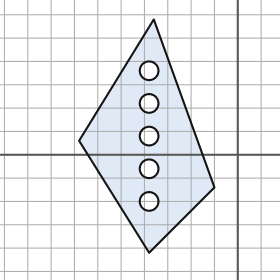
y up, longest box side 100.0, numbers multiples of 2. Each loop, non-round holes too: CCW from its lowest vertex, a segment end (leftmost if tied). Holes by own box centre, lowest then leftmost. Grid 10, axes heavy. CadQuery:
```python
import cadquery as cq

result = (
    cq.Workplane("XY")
    .moveTo(-38.0, -42.0)
    .lineTo(-10.0, -14.0)
    .lineTo(-36.0, 58.0)
    .lineTo(-68.0, 6.0)
    .close()
    .moveTo(-38.0, -20.0)
    .circle(4.0)
    .moveTo(-38.0, -6.0)
    .circle(4.0)
    .moveTo(-38.0, 8.0)
    .circle(4.0)
    .moveTo(-38.0, 22.0)
    .circle(4.0)
    .moveTo(-38.0, 36.0)
    .circle(4.0)
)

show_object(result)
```